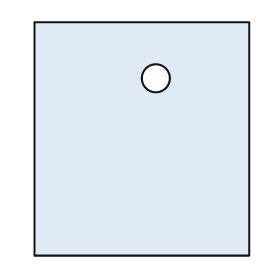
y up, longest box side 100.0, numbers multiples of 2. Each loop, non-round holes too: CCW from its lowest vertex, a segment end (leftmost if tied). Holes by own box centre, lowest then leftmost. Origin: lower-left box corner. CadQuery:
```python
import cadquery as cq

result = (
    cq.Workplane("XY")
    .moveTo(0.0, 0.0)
    .lineTo(92.0, 0.0)
    .lineTo(92.0, 100.0)
    .lineTo(0.0, 100.0)
    .close()
    .moveTo(52.0, 76.0)
    .circle(6.0)
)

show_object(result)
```